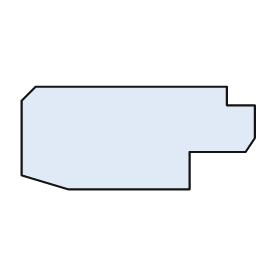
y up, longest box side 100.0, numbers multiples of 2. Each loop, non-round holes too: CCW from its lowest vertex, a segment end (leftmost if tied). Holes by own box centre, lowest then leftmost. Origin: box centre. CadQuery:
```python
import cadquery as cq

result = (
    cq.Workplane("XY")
    .moveTo(-30.0, -22.0)
    .lineTo(22.0, -22.0)
    .lineTo(22.0, -6.0)
    .lineTo(46.0, -6.0)
    .lineTo(50.0, 0.0)
    .lineTo(50.0, 14.0)
    .lineTo(38.0, 14.0)
    .lineTo(38.0, 22.0)
    .lineTo(-44.0, 22.0)
    .lineTo(-50.0, 16.0)
    .lineTo(-50.0, -16.0)
    .close()
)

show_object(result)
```